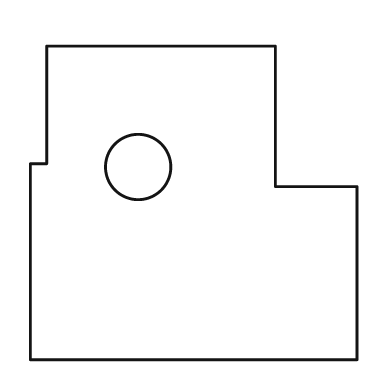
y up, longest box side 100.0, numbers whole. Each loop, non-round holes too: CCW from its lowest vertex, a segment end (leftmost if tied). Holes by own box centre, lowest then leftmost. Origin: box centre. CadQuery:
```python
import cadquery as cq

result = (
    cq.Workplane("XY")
    .moveTo(-50.0, -48.0)
    .lineTo(50.0, -48.0)
    .lineTo(50.0, 5.0)
    .lineTo(25.0, 5.0)
    .lineTo(25.0, 48.0)
    .lineTo(-45.0, 48.0)
    .lineTo(-45.0, 12.0)
    .lineTo(-50.0, 12.0)
    .close()
    .moveTo(-17.0, 11.0)
    .circle(10.0)
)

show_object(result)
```